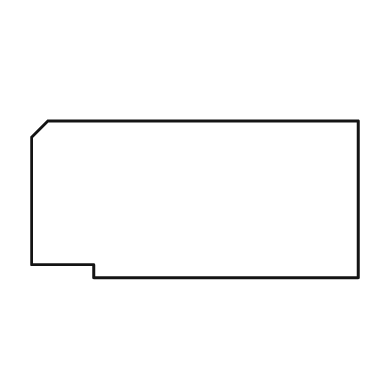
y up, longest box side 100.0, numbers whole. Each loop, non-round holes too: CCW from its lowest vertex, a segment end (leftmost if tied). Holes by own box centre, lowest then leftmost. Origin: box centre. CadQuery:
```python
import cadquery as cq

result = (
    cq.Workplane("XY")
    .moveTo(-31.0, -24.0)
    .lineTo(50.0, -24.0)
    .lineTo(50.0, 24.0)
    .lineTo(-45.0, 24.0)
    .lineTo(-50.0, 19.0)
    .lineTo(-50.0, -20.0)
    .lineTo(-31.0, -20.0)
    .close()
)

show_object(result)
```